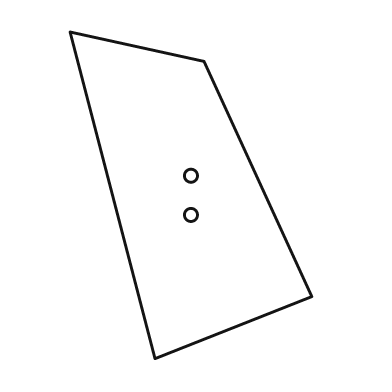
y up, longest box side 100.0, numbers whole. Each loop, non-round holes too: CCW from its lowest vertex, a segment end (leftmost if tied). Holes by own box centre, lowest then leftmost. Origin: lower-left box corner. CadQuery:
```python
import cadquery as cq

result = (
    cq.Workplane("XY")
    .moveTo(26.0, 0.0)
    .lineTo(74.0, 19.0)
    .lineTo(41.0, 91.0)
    .lineTo(0.0, 100.0)
    .close()
    .moveTo(37.0, 44.0)
    .circle(2.0)
    .moveTo(37.0, 56.0)
    .circle(2.0)
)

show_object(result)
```